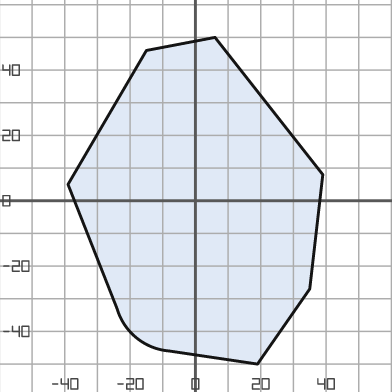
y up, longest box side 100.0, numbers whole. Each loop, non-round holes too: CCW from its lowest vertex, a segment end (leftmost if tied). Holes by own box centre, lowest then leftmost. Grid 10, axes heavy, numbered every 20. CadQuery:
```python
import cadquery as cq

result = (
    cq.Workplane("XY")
    .moveTo(19.0, -50.0)
    .lineTo(35.0, -27.0)
    .lineTo(39.0, 8.0)
    .lineTo(6.0, 50.0)
    .lineTo(-15.0, 46.0)
    .lineTo(-39.0, 5.0)
    .lineTo(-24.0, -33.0)
    .threePointArc((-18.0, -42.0), (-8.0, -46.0))
    .close()
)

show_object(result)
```